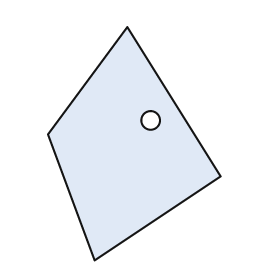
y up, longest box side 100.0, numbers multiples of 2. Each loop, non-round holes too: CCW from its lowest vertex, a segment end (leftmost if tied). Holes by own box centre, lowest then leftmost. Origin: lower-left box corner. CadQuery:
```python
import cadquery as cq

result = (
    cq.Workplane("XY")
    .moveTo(20.0, 0.0)
    .lineTo(74.0, 36.0)
    .lineTo(34.0, 100.0)
    .lineTo(0.0, 54.0)
    .close()
    .moveTo(44.0, 60.0)
    .circle(4.0)
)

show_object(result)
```